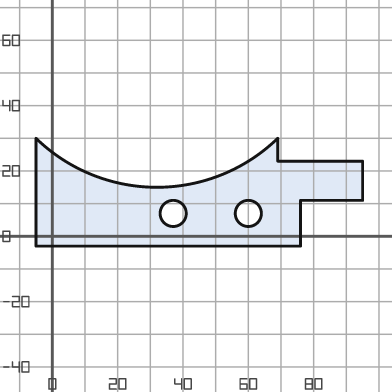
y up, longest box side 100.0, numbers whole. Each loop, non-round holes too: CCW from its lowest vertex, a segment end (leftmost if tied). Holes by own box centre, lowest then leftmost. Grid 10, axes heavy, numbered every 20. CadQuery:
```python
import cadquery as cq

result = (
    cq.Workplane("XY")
    .moveTo(-5.0, -3.0)
    .lineTo(76.0, -3.0)
    .lineTo(76.0, 11.0)
    .lineTo(95.0, 11.0)
    .lineTo(95.0, 23.0)
    .lineTo(69.0, 23.0)
    .lineTo(69.0, 30.0)
    .threePointArc((32.0, 15.0), (-5.0, 30.0))
    .close()
    .moveTo(37.0, 7.0)
    .circle(4.0)
    .moveTo(60.0, 7.0)
    .circle(4.0)
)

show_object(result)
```